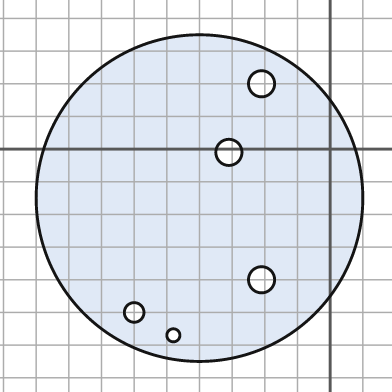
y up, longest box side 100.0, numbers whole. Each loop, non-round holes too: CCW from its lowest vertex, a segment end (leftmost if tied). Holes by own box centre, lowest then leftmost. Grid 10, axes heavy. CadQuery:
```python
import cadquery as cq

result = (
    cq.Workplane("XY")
    .moveTo(-40.0, -15.0)
    .circle(50.0)
    .moveTo(-48.0, -57.0)
    .circle(2.0)
    .moveTo(-60.0, -50.0)
    .circle(3.0)
    .moveTo(-21.0, -40.0)
    .circle(4.0)
    .moveTo(-31.0, -1.0)
    .circle(4.0)
    .moveTo(-21.0, 20.0)
    .circle(4.0)
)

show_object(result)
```